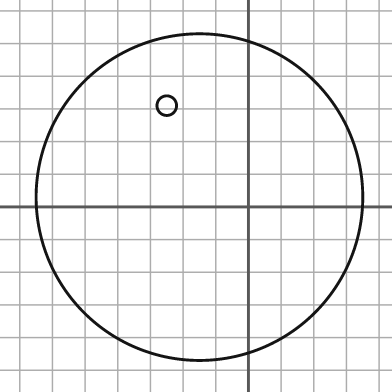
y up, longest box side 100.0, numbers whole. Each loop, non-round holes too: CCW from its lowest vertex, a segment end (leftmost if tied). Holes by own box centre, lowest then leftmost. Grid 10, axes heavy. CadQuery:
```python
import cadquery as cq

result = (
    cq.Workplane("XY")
    .moveTo(-15.0, 3.0)
    .circle(50.0)
    .moveTo(-25.0, 31.0)
    .circle(3.0)
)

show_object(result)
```